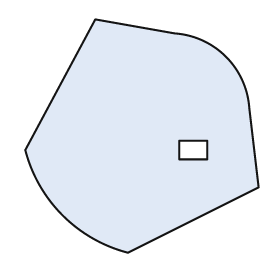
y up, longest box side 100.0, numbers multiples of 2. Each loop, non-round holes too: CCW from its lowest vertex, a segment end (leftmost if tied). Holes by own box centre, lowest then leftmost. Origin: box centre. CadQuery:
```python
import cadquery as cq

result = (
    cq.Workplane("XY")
    .moveTo(-6.0, -50.0)
    .lineTo(50.0, -22.0)
    .lineTo(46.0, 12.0)
    .threePointArc((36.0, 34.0), (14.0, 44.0))
    .lineTo(-20.0, 50.0)
    .lineTo(-50.0, -6.0)
    .threePointArc((-34.0, -34.0), (-6.0, -50.0))
    .close()
    .moveTo(16.0, -10.0)
    .lineTo(28.0, -10.0)
    .lineTo(28.0, -2.0)
    .lineTo(16.0, -2.0)
    .close()
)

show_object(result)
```